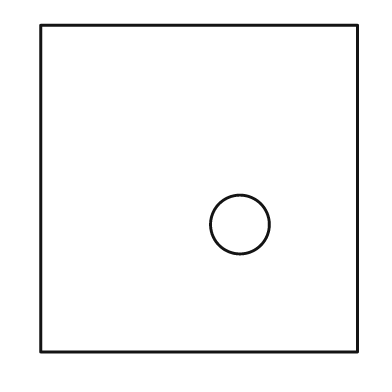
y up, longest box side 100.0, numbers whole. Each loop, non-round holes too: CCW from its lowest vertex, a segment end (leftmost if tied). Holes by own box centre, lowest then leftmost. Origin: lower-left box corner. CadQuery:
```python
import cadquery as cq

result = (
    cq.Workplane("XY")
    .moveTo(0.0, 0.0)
    .lineTo(97.0, 0.0)
    .lineTo(97.0, 100.0)
    .lineTo(0.0, 100.0)
    .close()
    .moveTo(61.0, 39.0)
    .circle(9.0)
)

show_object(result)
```